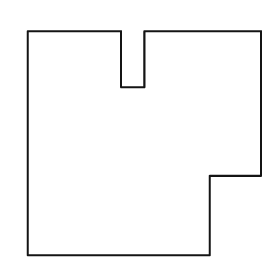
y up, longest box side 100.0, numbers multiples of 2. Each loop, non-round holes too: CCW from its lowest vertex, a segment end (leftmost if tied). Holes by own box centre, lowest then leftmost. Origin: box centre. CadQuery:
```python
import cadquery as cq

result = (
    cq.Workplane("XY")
    .moveTo(-50.0, -48.0)
    .lineTo(28.0, -48.0)
    .lineTo(28.0, -14.0)
    .lineTo(50.0, -14.0)
    .lineTo(50.0, 48.0)
    .lineTo(0.0, 48.0)
    .lineTo(0.0, 24.0)
    .lineTo(-10.0, 24.0)
    .lineTo(-10.0, 48.0)
    .lineTo(-50.0, 48.0)
    .close()
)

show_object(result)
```